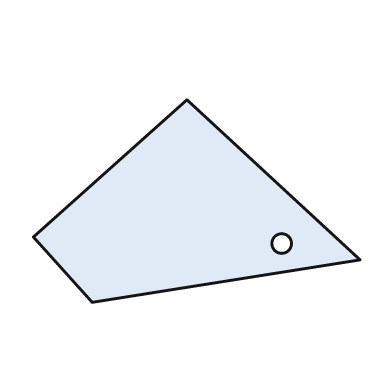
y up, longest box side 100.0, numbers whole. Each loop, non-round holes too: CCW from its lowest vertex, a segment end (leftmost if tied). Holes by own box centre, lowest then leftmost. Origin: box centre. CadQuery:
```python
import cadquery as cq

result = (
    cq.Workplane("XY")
    .moveTo(-32.0, -31.0)
    .lineTo(50.0, -18.0)
    .lineTo(-3.0, 31.0)
    .lineTo(-50.0, -11.0)
    .close()
    .moveTo(26.0, -13.0)
    .circle(3.0)
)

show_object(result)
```